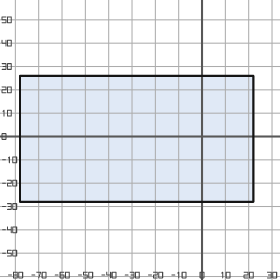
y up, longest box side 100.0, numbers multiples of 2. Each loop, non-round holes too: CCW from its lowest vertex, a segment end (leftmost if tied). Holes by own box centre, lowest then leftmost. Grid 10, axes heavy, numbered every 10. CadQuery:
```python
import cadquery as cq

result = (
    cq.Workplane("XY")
    .moveTo(-78.0, -28.0)
    .lineTo(22.0, -28.0)
    .lineTo(22.0, 26.0)
    .lineTo(-78.0, 26.0)
    .close()
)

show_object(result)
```